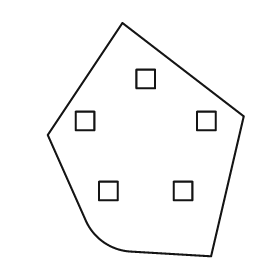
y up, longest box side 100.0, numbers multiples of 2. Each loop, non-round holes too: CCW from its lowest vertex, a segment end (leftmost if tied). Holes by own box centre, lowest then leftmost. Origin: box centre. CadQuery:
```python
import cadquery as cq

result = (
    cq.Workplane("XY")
    .moveTo(28.0, -50.0)
    .lineTo(42.0, 10.0)
    .lineTo(-10.0, 50.0)
    .lineTo(-42.0, 2.0)
    .lineTo(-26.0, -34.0)
    .threePointArc((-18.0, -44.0), (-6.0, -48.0))
    .close()
    .moveTo(-20.0, -26.0)
    .lineTo(-12.0, -26.0)
    .lineTo(-12.0, -18.0)
    .lineTo(-20.0, -18.0)
    .close()
    .moveTo(12.0, -26.0)
    .lineTo(20.0, -26.0)
    .lineTo(20.0, -18.0)
    .lineTo(12.0, -18.0)
    .close()
    .moveTo(-30.0, 4.0)
    .lineTo(-22.0, 4.0)
    .lineTo(-22.0, 12.0)
    .lineTo(-30.0, 12.0)
    .close()
    .moveTo(22.0, 4.0)
    .lineTo(30.0, 4.0)
    .lineTo(30.0, 12.0)
    .lineTo(22.0, 12.0)
    .close()
    .moveTo(-4.0, 22.0)
    .lineTo(4.0, 22.0)
    .lineTo(4.0, 30.0)
    .lineTo(-4.0, 30.0)
    .close()
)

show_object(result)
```